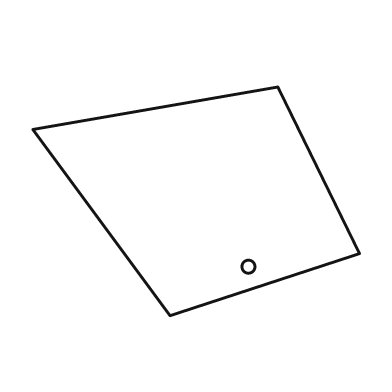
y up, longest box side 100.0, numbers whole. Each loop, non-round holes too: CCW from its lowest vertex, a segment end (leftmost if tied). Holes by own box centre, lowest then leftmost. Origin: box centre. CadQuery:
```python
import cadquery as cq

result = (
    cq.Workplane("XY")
    .moveTo(-8.0, -35.0)
    .lineTo(50.0, -16.0)
    .lineTo(25.0, 35.0)
    .lineTo(-50.0, 22.0)
    .close()
    .moveTo(16.0, -20.0)
    .circle(2.0)
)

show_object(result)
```